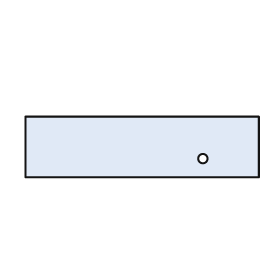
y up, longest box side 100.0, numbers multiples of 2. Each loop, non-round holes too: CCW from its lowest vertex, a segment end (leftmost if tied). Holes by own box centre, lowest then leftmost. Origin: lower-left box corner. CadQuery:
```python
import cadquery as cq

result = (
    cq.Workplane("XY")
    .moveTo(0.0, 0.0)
    .lineTo(100.0, 0.0)
    .lineTo(100.0, 26.0)
    .lineTo(0.0, 26.0)
    .close()
    .moveTo(76.0, 8.0)
    .circle(2.0)
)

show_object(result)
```